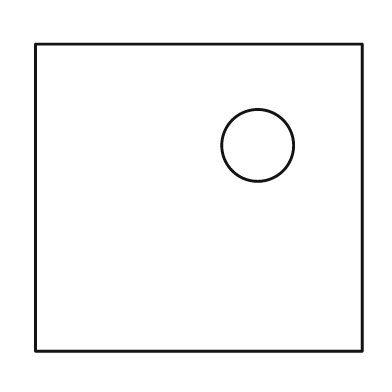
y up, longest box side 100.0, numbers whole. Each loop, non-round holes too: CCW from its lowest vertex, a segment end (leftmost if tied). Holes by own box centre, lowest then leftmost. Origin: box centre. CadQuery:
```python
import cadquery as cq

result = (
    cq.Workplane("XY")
    .moveTo(-50.0, -47.0)
    .lineTo(50.0, -47.0)
    .lineTo(50.0, 47.0)
    .lineTo(-50.0, 47.0)
    .close()
    .moveTo(18.0, 16.0)
    .circle(11.0)
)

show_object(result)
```